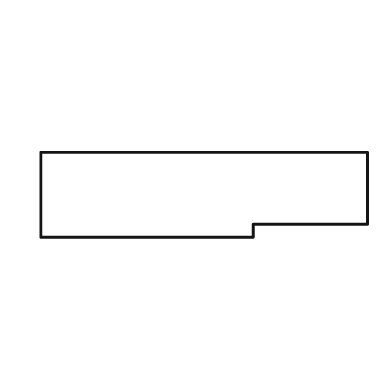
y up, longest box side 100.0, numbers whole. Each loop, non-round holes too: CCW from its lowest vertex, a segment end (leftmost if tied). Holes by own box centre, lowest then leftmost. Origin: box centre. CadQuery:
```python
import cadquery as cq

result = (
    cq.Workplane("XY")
    .moveTo(-50.0, -13.0)
    .lineTo(15.0, -13.0)
    .lineTo(15.0, -9.0)
    .lineTo(50.0, -9.0)
    .lineTo(50.0, 13.0)
    .lineTo(-50.0, 13.0)
    .close()
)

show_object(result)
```